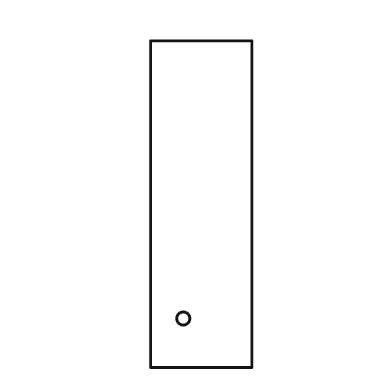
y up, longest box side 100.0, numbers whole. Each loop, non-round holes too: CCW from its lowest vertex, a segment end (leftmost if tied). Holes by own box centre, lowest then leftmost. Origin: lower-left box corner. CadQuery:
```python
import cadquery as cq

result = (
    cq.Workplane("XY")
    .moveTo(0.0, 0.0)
    .lineTo(31.0, 0.0)
    .lineTo(31.0, 100.0)
    .lineTo(0.0, 100.0)
    .close()
    .moveTo(10.0, 15.0)
    .circle(2.0)
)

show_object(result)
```